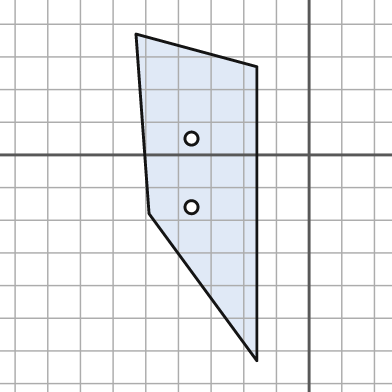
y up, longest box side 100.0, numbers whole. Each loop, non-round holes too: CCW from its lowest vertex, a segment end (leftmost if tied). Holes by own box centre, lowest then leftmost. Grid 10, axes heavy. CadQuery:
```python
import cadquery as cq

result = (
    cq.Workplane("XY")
    .moveTo(-16.0, -63.0)
    .lineTo(-16.0, 27.0)
    .lineTo(-53.0, 37.0)
    .lineTo(-49.0, -18.0)
    .close()
    .moveTo(-36.0, -16.0)
    .circle(2.0)
    .moveTo(-36.0, 5.0)
    .circle(2.0)
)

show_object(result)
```